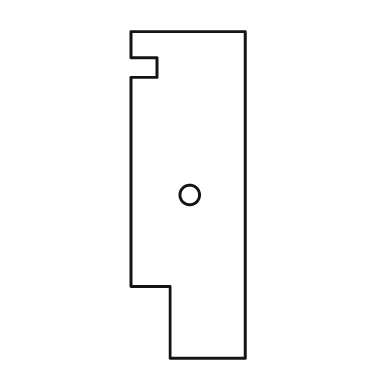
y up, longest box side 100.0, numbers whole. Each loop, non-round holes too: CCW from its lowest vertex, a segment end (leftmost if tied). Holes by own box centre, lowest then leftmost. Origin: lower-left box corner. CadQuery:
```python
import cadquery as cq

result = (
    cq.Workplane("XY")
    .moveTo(12.0, 0.0)
    .lineTo(35.0, 0.0)
    .lineTo(35.0, 100.0)
    .lineTo(0.0, 100.0)
    .lineTo(0.0, 92.0)
    .lineTo(8.0, 92.0)
    .lineTo(8.0, 86.0)
    .lineTo(0.0, 86.0)
    .lineTo(0.0, 22.0)
    .lineTo(12.0, 22.0)
    .close()
    .moveTo(18.0, 50.0)
    .circle(3.0)
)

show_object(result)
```